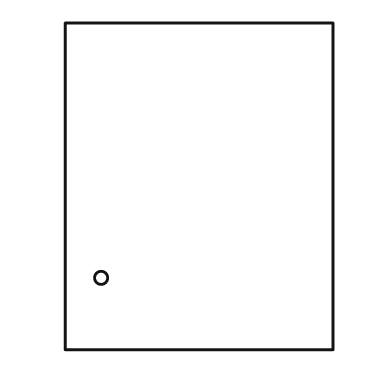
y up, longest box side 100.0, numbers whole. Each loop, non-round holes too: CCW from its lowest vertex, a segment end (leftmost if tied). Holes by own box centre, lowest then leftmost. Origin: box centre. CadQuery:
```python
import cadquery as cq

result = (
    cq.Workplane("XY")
    .moveTo(-41.0, -50.0)
    .lineTo(41.0, -50.0)
    .lineTo(41.0, 50.0)
    .lineTo(-41.0, 50.0)
    .close()
    .moveTo(-30.0, -28.0)
    .circle(2.0)
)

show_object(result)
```